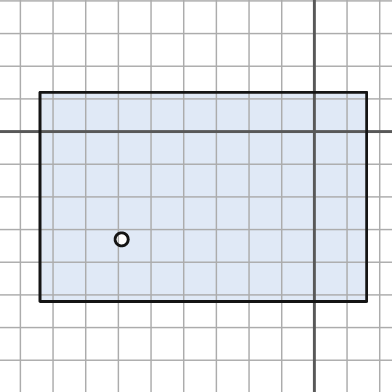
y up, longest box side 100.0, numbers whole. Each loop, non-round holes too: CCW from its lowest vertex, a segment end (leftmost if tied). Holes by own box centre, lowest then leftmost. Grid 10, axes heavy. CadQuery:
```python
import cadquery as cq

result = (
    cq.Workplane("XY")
    .moveTo(-84.0, -52.0)
    .lineTo(16.0, -52.0)
    .lineTo(16.0, 12.0)
    .lineTo(-84.0, 12.0)
    .close()
    .moveTo(-59.0, -33.0)
    .circle(2.0)
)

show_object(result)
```